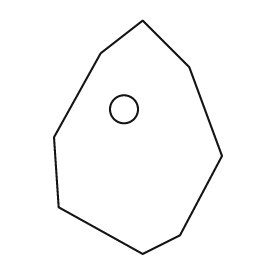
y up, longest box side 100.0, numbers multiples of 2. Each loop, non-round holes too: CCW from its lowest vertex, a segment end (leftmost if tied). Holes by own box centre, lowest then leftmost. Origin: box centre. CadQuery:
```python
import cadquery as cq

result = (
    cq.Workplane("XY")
    .moveTo(2.0, -50.0)
    .lineTo(18.0, -42.0)
    .lineTo(36.0, -8.0)
    .lineTo(22.0, 30.0)
    .lineTo(2.0, 50.0)
    .lineTo(-16.0, 36.0)
    .lineTo(-36.0, 0.0)
    .lineTo(-34.0, -30.0)
    .close()
    .moveTo(-6.0, 12.0)
    .circle(6.0)
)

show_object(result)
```